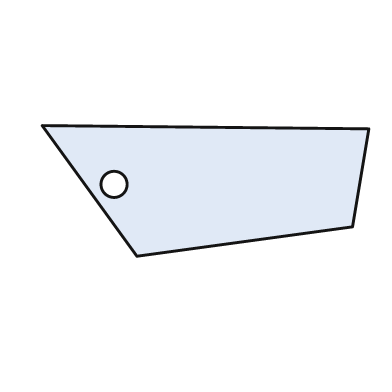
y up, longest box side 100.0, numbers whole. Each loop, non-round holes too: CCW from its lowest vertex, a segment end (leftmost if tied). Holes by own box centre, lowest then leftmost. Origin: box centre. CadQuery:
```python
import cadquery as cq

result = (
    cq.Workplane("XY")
    .moveTo(-21.0, -20.0)
    .lineTo(45.0, -11.0)
    .lineTo(50.0, 19.0)
    .lineTo(-50.0, 20.0)
    .close()
    .moveTo(-28.0, 2.0)
    .circle(4.0)
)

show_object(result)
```